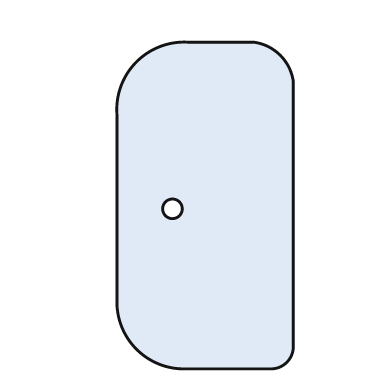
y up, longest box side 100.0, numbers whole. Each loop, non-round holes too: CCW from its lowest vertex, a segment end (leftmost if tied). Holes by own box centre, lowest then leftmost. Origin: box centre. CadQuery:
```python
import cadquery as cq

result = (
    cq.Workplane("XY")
    .moveTo(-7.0, -50.0)
    .lineTo(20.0, -50.0)
    .threePointArc((25.0, -48.0), (27.0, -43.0))
    .lineTo(27.0, 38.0)
    .threePointArc((23.0, 46.0), (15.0, 50.0))
    .lineTo(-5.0, 50.0)
    .threePointArc((-21.0, 44.0), (-27.0, 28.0))
    .lineTo(-27.0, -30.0)
    .threePointArc((-21.0, -44.0), (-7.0, -50.0))
    .close()
    .moveTo(-10.0, -1.0)
    .circle(3.0)
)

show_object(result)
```